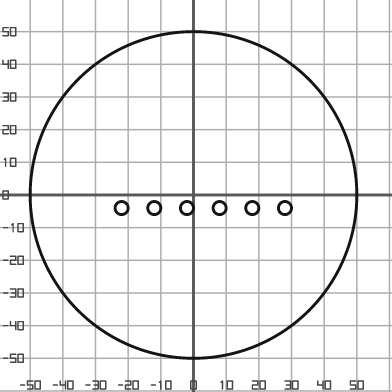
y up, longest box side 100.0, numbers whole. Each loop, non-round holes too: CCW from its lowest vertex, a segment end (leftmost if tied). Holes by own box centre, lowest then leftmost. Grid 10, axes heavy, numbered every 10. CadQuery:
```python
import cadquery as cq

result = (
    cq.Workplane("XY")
    .moveTo(0.0, 0.0)
    .circle(50.0)
    .moveTo(-22.0, -4.0)
    .circle(2.0)
    .moveTo(-12.0, -4.0)
    .circle(2.0)
    .moveTo(-2.0, -4.0)
    .circle(2.0)
    .moveTo(8.0, -4.0)
    .circle(2.0)
    .moveTo(18.0, -4.0)
    .circle(2.0)
    .moveTo(28.0, -4.0)
    .circle(2.0)
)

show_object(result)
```